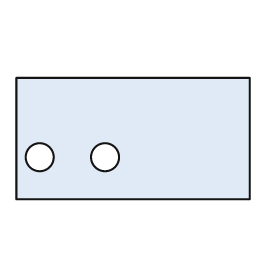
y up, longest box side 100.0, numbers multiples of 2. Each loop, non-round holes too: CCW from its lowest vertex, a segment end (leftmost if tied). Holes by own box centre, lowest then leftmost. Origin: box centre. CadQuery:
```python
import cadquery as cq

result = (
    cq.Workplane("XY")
    .moveTo(-50.0, -26.0)
    .lineTo(50.0, -26.0)
    .lineTo(50.0, 26.0)
    .lineTo(-50.0, 26.0)
    .close()
    .moveTo(-40.0, -8.0)
    .circle(6.0)
    .moveTo(-12.0, -8.0)
    .circle(6.0)
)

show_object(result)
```